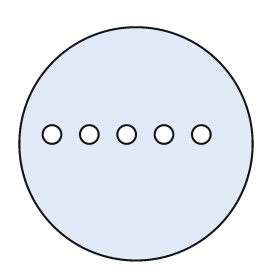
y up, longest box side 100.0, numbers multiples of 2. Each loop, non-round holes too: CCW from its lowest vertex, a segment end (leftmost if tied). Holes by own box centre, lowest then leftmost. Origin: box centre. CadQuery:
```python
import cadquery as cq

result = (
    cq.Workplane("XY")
    .moveTo(0.0, 0.0)
    .circle(50.0)
    .moveTo(-36.0, 4.0)
    .circle(4.0)
    .moveTo(-20.0, 4.0)
    .circle(4.0)
    .moveTo(-4.0, 4.0)
    .circle(4.0)
    .moveTo(12.0, 4.0)
    .circle(4.0)
    .moveTo(28.0, 4.0)
    .circle(4.0)
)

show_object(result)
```